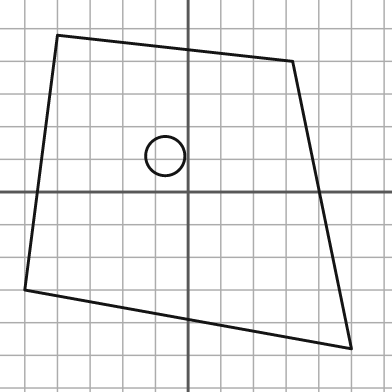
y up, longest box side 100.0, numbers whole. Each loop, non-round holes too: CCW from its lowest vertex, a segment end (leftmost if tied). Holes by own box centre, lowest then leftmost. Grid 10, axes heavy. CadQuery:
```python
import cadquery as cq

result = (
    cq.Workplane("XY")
    .moveTo(50.0, -48.0)
    .lineTo(32.0, 40.0)
    .lineTo(-40.0, 48.0)
    .lineTo(-50.0, -30.0)
    .close()
    .moveTo(-7.0, 11.0)
    .circle(6.0)
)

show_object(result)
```